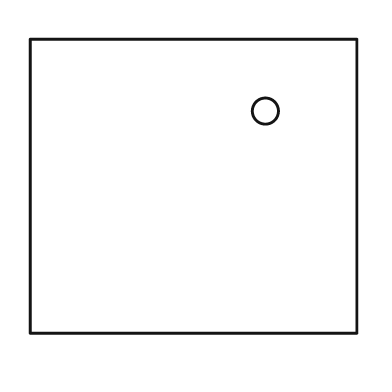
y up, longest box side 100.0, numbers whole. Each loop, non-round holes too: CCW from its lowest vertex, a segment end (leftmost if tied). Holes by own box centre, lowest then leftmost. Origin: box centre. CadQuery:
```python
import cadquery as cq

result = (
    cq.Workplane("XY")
    .moveTo(-50.0, -45.0)
    .lineTo(50.0, -45.0)
    .lineTo(50.0, 45.0)
    .lineTo(-50.0, 45.0)
    .close()
    .moveTo(22.0, 23.0)
    .circle(4.0)
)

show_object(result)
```